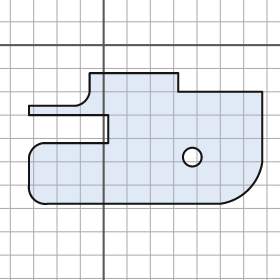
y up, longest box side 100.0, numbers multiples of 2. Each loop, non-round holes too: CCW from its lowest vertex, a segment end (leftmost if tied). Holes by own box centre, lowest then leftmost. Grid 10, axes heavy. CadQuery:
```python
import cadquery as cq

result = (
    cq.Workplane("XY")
    .moveTo(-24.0, -68.0)
    .lineTo(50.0, -68.0)
    .threePointArc((62.0, -62.0), (68.0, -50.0))
    .lineTo(68.0, -20.0)
    .lineTo(32.0, -20.0)
    .lineTo(32.0, -12.0)
    .lineTo(-6.0, -12.0)
    .lineTo(-6.0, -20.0)
    .threePointArc((-8.0, -24.0), (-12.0, -26.0))
    .lineTo(-32.0, -26.0)
    .lineTo(-32.0, -30.0)
    .lineTo(2.0, -30.0)
    .lineTo(2.0, -42.0)
    .lineTo(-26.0, -42.0)
    .threePointArc((-30.0, -44.0), (-32.0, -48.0))
    .lineTo(-32.0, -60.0)
    .threePointArc((-30.0, -66.0), (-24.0, -68.0))
    .close()
    .moveTo(38.0, -48.0)
    .circle(4.0)
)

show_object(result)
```